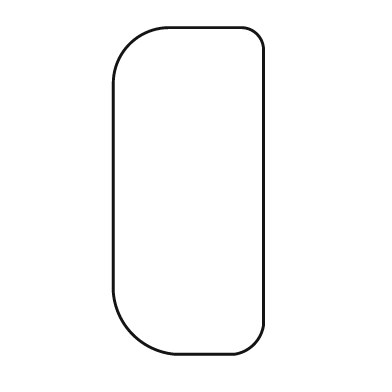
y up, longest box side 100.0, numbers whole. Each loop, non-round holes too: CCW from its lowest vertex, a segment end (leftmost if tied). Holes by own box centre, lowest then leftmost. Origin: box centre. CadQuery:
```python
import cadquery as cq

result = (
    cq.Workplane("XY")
    .moveTo(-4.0, -50.0)
    .lineTo(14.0, -50.0)
    .threePointArc((20.0, -47.0), (23.0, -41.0))
    .lineTo(23.0, 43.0)
    .threePointArc((21.0, 48.0), (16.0, 50.0))
    .lineTo(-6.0, 50.0)
    .threePointArc((-18.0, 45.0), (-23.0, 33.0))
    .lineTo(-23.0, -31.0)
    .threePointArc((-17.0, -44.0), (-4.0, -50.0))
    .close()
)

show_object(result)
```